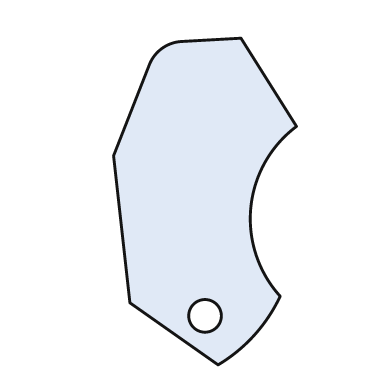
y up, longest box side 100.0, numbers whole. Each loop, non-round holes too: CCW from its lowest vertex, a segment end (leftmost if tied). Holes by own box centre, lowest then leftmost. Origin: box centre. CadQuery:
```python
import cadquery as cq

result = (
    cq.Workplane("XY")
    .moveTo(4.0, -50.0)
    .threePointArc((15.0, -41.0), (23.0, -29.0))
    .threePointArc((14.0, -2.0), (28.0, 23.0))
    .lineTo(11.0, 50.0)
    .lineTo(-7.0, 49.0)
    .threePointArc((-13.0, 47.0), (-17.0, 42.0))
    .lineTo(-28.0, 14.0)
    .lineTo(-23.0, -31.0)
    .close()
    .moveTo(0.0, -35.0)
    .circle(5.0)
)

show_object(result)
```